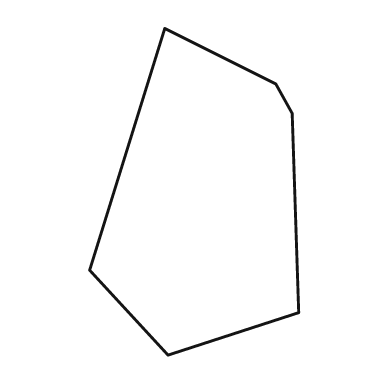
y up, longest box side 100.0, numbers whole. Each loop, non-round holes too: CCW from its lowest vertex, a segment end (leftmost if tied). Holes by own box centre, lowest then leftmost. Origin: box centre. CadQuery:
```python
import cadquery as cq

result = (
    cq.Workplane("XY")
    .moveTo(-8.0, -50.0)
    .lineTo(32.0, -37.0)
    .lineTo(30.0, 24.0)
    .lineTo(25.0, 33.0)
    .lineTo(-9.0, 50.0)
    .lineTo(-32.0, -24.0)
    .close()
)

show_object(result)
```